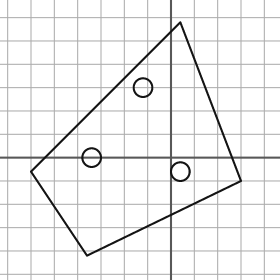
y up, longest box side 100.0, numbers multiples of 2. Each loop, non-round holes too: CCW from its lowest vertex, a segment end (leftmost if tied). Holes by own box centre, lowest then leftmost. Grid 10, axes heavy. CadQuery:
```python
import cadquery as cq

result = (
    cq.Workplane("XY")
    .moveTo(-36.0, -42.0)
    .lineTo(30.0, -10.0)
    .lineTo(4.0, 58.0)
    .lineTo(-60.0, -6.0)
    .close()
    .moveTo(4.0, -6.0)
    .circle(4.0)
    .moveTo(-34.0, 0.0)
    .circle(4.0)
    .moveTo(-12.0, 30.0)
    .circle(4.0)
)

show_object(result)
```